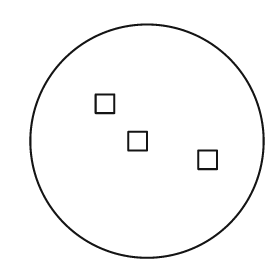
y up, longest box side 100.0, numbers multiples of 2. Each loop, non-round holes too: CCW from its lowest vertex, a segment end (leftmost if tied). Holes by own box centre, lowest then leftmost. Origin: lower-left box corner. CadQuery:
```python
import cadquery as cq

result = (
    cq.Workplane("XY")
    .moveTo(50.0, 50.0)
    .circle(50.0)
    .moveTo(72.0, 38.0)
    .lineTo(80.0, 38.0)
    .lineTo(80.0, 46.0)
    .lineTo(72.0, 46.0)
    .close()
    .moveTo(42.0, 46.0)
    .lineTo(50.0, 46.0)
    .lineTo(50.0, 54.0)
    .lineTo(42.0, 54.0)
    .close()
    .moveTo(28.0, 62.0)
    .lineTo(36.0, 62.0)
    .lineTo(36.0, 70.0)
    .lineTo(28.0, 70.0)
    .close()
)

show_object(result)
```